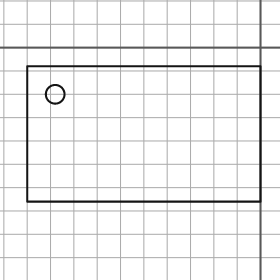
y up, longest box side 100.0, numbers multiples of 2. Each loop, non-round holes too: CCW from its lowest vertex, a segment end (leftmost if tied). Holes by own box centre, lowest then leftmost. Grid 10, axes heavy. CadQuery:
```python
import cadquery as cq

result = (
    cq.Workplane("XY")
    .moveTo(-100.0, -66.0)
    .lineTo(0.0, -66.0)
    .lineTo(0.0, -8.0)
    .lineTo(-100.0, -8.0)
    .close()
    .moveTo(-88.0, -20.0)
    .circle(4.0)
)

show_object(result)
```